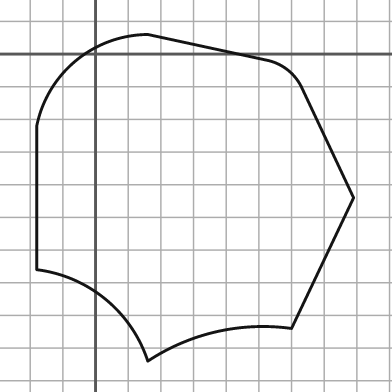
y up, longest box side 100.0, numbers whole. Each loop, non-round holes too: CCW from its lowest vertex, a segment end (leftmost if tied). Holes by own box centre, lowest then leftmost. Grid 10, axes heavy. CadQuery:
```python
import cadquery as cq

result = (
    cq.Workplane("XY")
    .moveTo(16.0, -94.0)
    .threePointArc((37.0, -85.0), (60.0, -84.0))
    .lineTo(79.0, -44.0)
    .lineTo(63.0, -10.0)
    .threePointArc((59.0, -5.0), (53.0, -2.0))
    .lineTo(16.0, 6.0)
    .threePointArc((-6.0, -2.0), (-18.0, -22.0))
    .lineTo(-18.0, -66.0)
    .threePointArc((3.0, -75.0), (16.0, -94.0))
    .close()
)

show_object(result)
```